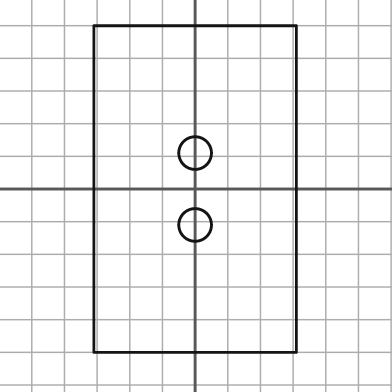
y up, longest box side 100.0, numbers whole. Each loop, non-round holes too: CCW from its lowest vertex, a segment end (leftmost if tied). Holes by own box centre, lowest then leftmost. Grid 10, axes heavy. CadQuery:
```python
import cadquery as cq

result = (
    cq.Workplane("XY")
    .moveTo(-31.0, -50.0)
    .lineTo(31.0, -50.0)
    .lineTo(31.0, 50.0)
    .lineTo(-31.0, 50.0)
    .close()
    .moveTo(0.0, -11.0)
    .circle(5.0)
    .moveTo(0.0, 11.0)
    .circle(5.0)
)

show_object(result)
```